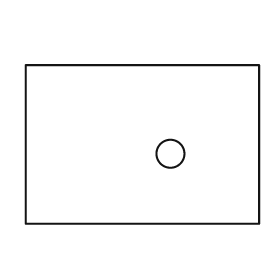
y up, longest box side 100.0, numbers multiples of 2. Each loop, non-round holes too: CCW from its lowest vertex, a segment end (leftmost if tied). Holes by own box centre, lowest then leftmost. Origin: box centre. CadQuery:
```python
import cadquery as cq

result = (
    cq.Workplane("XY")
    .moveTo(-50.0, -34.0)
    .lineTo(50.0, -34.0)
    .lineTo(50.0, 34.0)
    .lineTo(-50.0, 34.0)
    .close()
    .moveTo(12.0, -4.0)
    .circle(6.0)
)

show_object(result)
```